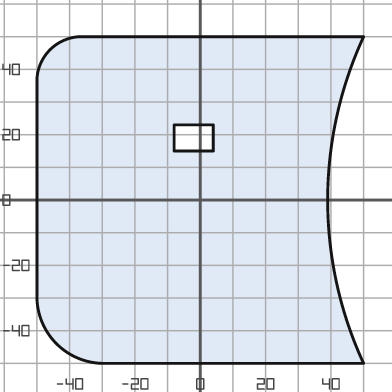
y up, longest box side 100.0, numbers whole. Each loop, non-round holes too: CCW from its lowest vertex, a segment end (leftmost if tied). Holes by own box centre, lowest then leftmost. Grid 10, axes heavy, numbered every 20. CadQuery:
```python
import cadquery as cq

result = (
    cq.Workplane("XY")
    .moveTo(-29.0, -50.0)
    .lineTo(50.0, -50.0)
    .threePointArc((39.0, 0.0), (50.0, 50.0))
    .lineTo(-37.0, 50.0)
    .threePointArc((-46.0, 46.0), (-50.0, 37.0))
    .lineTo(-50.0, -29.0)
    .threePointArc((-44.0, -44.0), (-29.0, -50.0))
    .close()
    .moveTo(-8.0, 15.0)
    .lineTo(4.0, 15.0)
    .lineTo(4.0, 23.0)
    .lineTo(-8.0, 23.0)
    .close()
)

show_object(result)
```